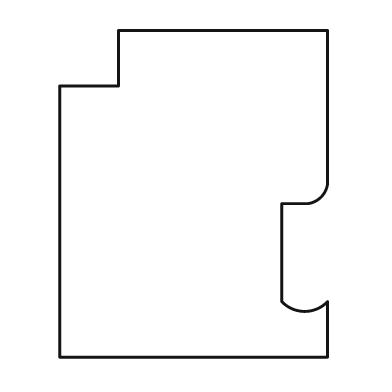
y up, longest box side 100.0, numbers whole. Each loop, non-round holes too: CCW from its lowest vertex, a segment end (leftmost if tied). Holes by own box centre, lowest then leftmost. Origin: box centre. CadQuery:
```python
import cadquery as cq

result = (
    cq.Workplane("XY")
    .moveTo(-41.0, -50.0)
    .lineTo(41.0, -50.0)
    .lineTo(41.0, -33.0)
    .threePointArc((34.0, -36.0), (27.0, -33.0))
    .lineTo(27.0, -3.0)
    .lineTo(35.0, -3.0)
    .threePointArc((39.0, -1.0), (41.0, 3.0))
    .lineTo(41.0, 50.0)
    .lineTo(-23.0, 50.0)
    .lineTo(-23.0, 33.0)
    .lineTo(-41.0, 33.0)
    .close()
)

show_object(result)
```